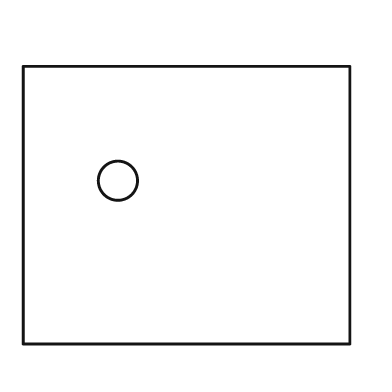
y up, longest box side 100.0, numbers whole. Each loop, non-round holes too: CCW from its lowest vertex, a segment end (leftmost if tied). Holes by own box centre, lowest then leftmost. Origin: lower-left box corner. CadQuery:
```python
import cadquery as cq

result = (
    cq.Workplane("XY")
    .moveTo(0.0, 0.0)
    .lineTo(100.0, 0.0)
    .lineTo(100.0, 85.0)
    .lineTo(0.0, 85.0)
    .close()
    .moveTo(29.0, 50.0)
    .circle(6.0)
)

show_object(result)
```